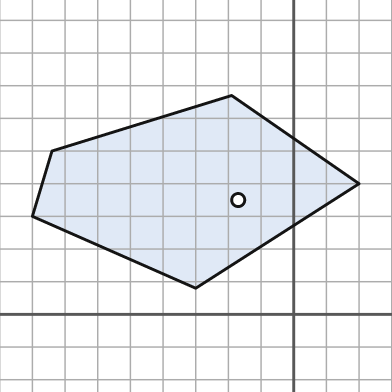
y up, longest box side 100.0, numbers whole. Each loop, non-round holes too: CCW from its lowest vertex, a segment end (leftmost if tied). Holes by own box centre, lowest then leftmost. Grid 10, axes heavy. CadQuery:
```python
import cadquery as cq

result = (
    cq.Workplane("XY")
    .moveTo(-30.0, 8.0)
    .lineTo(20.0, 40.0)
    .lineTo(-19.0, 67.0)
    .lineTo(-74.0, 50.0)
    .lineTo(-80.0, 30.0)
    .close()
    .moveTo(-17.0, 35.0)
    .circle(2.0)
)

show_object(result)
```